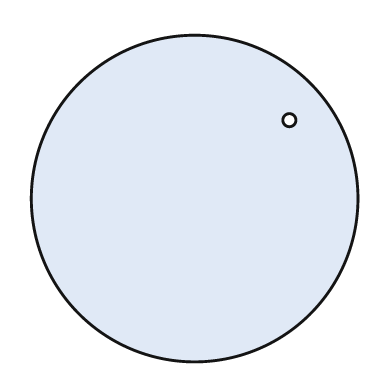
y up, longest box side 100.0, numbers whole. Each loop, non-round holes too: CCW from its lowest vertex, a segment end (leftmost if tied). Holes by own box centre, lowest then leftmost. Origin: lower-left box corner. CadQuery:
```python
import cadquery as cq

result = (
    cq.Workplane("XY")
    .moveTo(50.0, 50.0)
    .circle(50.0)
    .moveTo(79.0, 74.0)
    .circle(2.0)
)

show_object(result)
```